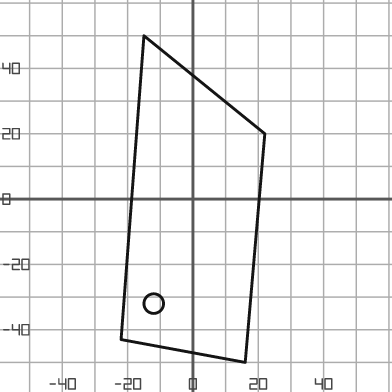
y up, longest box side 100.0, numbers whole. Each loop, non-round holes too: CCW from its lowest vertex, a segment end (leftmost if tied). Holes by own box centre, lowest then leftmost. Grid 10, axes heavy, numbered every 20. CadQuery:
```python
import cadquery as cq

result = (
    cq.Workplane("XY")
    .moveTo(16.0, -50.0)
    .lineTo(22.0, 20.0)
    .lineTo(-15.0, 50.0)
    .lineTo(-22.0, -43.0)
    .close()
    .moveTo(-12.0, -32.0)
    .circle(3.0)
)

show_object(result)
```